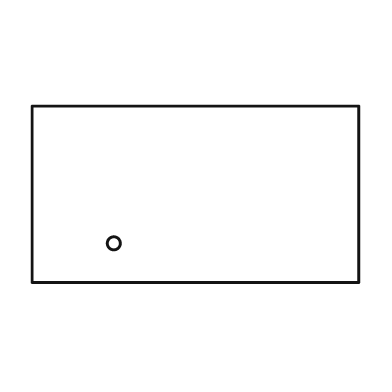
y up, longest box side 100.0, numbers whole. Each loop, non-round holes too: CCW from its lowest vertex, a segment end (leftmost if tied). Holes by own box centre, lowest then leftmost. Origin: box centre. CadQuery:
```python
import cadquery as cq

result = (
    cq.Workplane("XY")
    .moveTo(-50.0, -27.0)
    .lineTo(50.0, -27.0)
    .lineTo(50.0, 27.0)
    .lineTo(-50.0, 27.0)
    .close()
    .moveTo(-25.0, -15.0)
    .circle(2.0)
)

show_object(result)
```